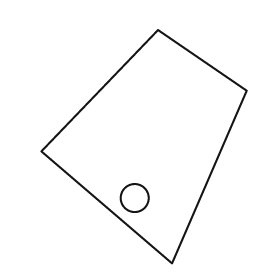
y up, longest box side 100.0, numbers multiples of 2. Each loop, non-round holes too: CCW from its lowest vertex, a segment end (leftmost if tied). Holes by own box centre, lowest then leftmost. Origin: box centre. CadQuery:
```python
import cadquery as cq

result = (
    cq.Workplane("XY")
    .moveTo(12.0, -50.0)
    .lineTo(44.0, 24.0)
    .lineTo(6.0, 50.0)
    .lineTo(-44.0, -2.0)
    .close()
    .moveTo(-4.0, -22.0)
    .circle(6.0)
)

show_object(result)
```